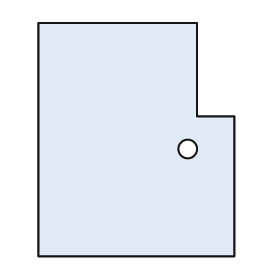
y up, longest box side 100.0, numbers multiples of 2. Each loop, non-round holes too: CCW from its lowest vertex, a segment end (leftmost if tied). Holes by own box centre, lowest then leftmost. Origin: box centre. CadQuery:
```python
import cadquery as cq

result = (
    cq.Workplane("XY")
    .moveTo(-42.0, -50.0)
    .lineTo(42.0, -50.0)
    .lineTo(42.0, 10.0)
    .lineTo(26.0, 10.0)
    .lineTo(26.0, 50.0)
    .lineTo(-42.0, 50.0)
    .close()
    .moveTo(22.0, -4.0)
    .circle(4.0)
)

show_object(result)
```